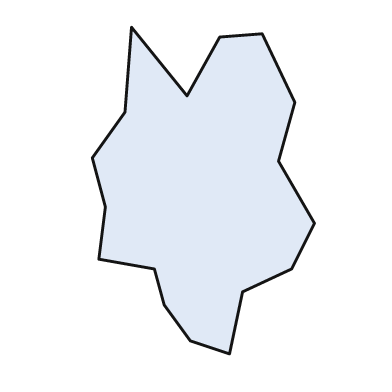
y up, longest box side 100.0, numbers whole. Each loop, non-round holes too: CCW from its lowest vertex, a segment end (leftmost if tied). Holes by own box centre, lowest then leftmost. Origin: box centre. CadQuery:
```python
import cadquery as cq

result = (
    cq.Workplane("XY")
    .moveTo(8.0, -50.0)
    .lineTo(12.0, -31.0)
    .lineTo(27.0, -24.0)
    .lineTo(34.0, -10.0)
    .lineTo(23.0, 9.0)
    .lineTo(28.0, 27.0)
    .lineTo(18.0, 48.0)
    .lineTo(5.0, 47.0)
    .lineTo(-5.0, 29.0)
    .lineTo(-22.0, 50.0)
    .lineTo(-24.0, 24.0)
    .lineTo(-34.0, 10.0)
    .lineTo(-30.0, -5.0)
    .lineTo(-32.0, -21.0)
    .lineTo(-15.0, -24.0)
    .lineTo(-12.0, -35.0)
    .lineTo(-4.0, -46.0)
    .close()
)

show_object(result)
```